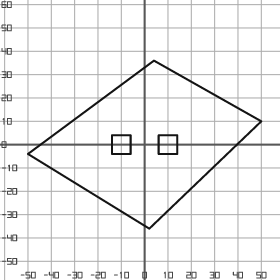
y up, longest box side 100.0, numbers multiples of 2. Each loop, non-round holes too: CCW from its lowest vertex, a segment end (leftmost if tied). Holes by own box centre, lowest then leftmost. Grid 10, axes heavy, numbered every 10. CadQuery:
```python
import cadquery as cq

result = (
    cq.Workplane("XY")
    .moveTo(2.0, -36.0)
    .lineTo(50.0, 10.0)
    .lineTo(4.0, 36.0)
    .lineTo(-50.0, -4.0)
    .close()
    .moveTo(-14.0, -4.0)
    .lineTo(-6.0, -4.0)
    .lineTo(-6.0, 4.0)
    .lineTo(-14.0, 4.0)
    .close()
    .moveTo(6.0, -4.0)
    .lineTo(14.0, -4.0)
    .lineTo(14.0, 4.0)
    .lineTo(6.0, 4.0)
    .close()
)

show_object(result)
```